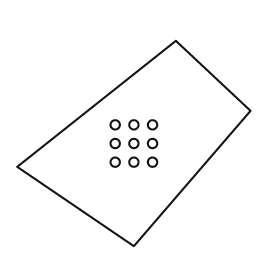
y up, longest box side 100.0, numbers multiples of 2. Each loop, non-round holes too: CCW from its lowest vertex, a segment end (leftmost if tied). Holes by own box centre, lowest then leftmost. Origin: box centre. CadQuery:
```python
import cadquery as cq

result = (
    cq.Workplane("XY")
    .moveTo(0.0, -44.0)
    .lineTo(50.0, 14.0)
    .lineTo(18.0, 44.0)
    .lineTo(-50.0, -10.0)
    .close()
    .moveTo(-8.0, -8.0)
    .circle(2.0)
    .moveTo(0.0, -8.0)
    .circle(2.0)
    .moveTo(8.0, -8.0)
    .circle(2.0)
    .moveTo(-8.0, 0.0)
    .circle(2.0)
    .moveTo(0.0, 0.0)
    .circle(2.0)
    .moveTo(8.0, 0.0)
    .circle(2.0)
    .moveTo(-8.0, 8.0)
    .circle(2.0)
    .moveTo(0.0, 8.0)
    .circle(2.0)
    .moveTo(8.0, 8.0)
    .circle(2.0)
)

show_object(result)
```